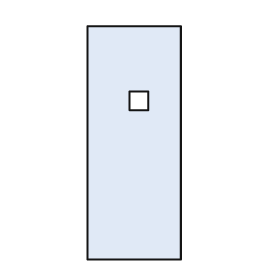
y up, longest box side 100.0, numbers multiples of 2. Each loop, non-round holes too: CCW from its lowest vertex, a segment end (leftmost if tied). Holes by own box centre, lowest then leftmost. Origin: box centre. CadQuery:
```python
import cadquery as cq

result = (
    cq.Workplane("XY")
    .moveTo(-20.0, -50.0)
    .lineTo(20.0, -50.0)
    .lineTo(20.0, 50.0)
    .lineTo(-20.0, 50.0)
    .close()
    .moveTo(-2.0, 14.0)
    .lineTo(6.0, 14.0)
    .lineTo(6.0, 22.0)
    .lineTo(-2.0, 22.0)
    .close()
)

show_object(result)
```